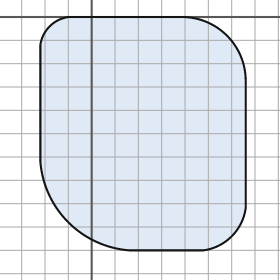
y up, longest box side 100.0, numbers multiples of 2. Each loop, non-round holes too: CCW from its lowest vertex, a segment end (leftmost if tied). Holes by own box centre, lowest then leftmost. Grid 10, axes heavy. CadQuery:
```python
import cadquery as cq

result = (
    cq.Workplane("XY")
    .moveTo(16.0, -100.0)
    .lineTo(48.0, -100.0)
    .threePointArc((60.0, -94.0), (66.0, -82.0))
    .lineTo(66.0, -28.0)
    .threePointArc((58.0, -8.0), (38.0, 0.0))
    .lineTo(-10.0, 0.0)
    .threePointArc((-18.0, -4.0), (-22.0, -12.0))
    .lineTo(-22.0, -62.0)
    .threePointArc((-10.0, -88.0), (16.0, -100.0))
    .close()
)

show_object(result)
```